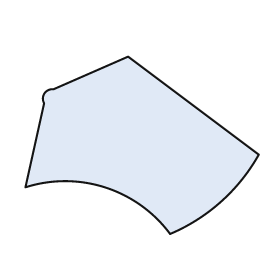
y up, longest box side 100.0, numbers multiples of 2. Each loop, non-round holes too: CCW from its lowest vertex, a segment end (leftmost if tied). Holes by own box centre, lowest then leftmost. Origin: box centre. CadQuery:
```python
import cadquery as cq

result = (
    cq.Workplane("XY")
    .moveTo(12.0, -38.0)
    .threePointArc((34.0, -24.0), (50.0, -4.0))
    .lineTo(-6.0, 38.0)
    .lineTo(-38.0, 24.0)
    .threePointArc((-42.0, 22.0), (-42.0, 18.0))
    .lineTo(-50.0, -18.0)
    .threePointArc((-16.0, -18.0), (12.0, -38.0))
    .close()
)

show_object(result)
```